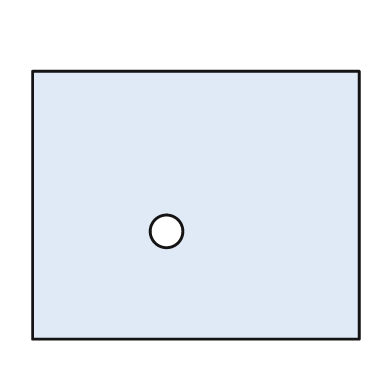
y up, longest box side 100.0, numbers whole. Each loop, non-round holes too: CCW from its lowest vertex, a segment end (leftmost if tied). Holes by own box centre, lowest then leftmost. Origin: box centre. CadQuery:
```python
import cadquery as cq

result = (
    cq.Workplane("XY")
    .moveTo(-50.0, -41.0)
    .lineTo(50.0, -41.0)
    .lineTo(50.0, 41.0)
    .lineTo(-50.0, 41.0)
    .close()
    .moveTo(-9.0, -8.0)
    .circle(5.0)
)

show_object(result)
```